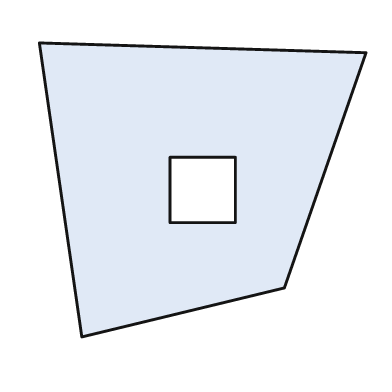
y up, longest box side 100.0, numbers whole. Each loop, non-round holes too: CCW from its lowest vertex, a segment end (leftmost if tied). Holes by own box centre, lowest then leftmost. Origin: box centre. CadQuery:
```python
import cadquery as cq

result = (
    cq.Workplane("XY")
    .moveTo(-37.0, -45.0)
    .lineTo(25.0, -30.0)
    .lineTo(50.0, 42.0)
    .lineTo(-50.0, 45.0)
    .close()
    .moveTo(-10.0, -10.0)
    .lineTo(10.0, -10.0)
    .lineTo(10.0, 10.0)
    .lineTo(-10.0, 10.0)
    .close()
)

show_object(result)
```